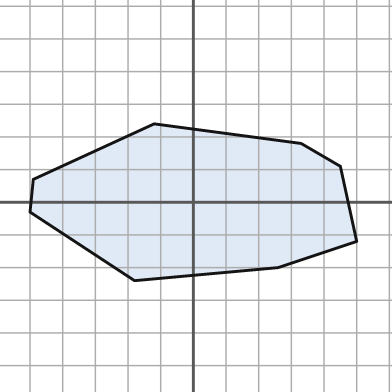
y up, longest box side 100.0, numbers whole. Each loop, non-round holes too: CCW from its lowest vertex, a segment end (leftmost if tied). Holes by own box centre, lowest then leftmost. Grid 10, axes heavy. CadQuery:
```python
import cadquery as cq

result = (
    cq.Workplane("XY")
    .moveTo(-18.0, -24.0)
    .lineTo(26.0, -20.0)
    .lineTo(50.0, -12.0)
    .lineTo(45.0, 11.0)
    .lineTo(33.0, 18.0)
    .lineTo(-12.0, 24.0)
    .lineTo(-49.0, 7.0)
    .lineTo(-50.0, -3.0)
    .close()
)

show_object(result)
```